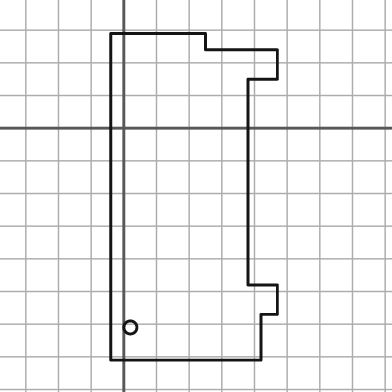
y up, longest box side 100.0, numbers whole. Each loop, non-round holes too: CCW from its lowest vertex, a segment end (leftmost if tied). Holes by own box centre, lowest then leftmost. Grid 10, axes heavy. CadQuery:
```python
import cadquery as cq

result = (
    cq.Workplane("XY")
    .moveTo(-4.0, -71.0)
    .lineTo(42.0, -71.0)
    .lineTo(42.0, -57.0)
    .lineTo(47.0, -57.0)
    .lineTo(47.0, -48.0)
    .lineTo(38.0, -48.0)
    .lineTo(38.0, 15.0)
    .lineTo(47.0, 15.0)
    .lineTo(47.0, 24.0)
    .lineTo(25.0, 24.0)
    .lineTo(25.0, 29.0)
    .lineTo(-4.0, 29.0)
    .close()
    .moveTo(2.0, -61.0)
    .circle(2.0)
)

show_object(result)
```